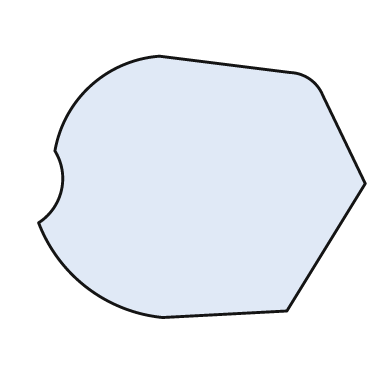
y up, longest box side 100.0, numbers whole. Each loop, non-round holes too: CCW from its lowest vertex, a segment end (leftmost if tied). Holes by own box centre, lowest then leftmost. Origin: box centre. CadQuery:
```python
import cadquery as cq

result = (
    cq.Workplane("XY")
    .moveTo(-12.0, -40.0)
    .lineTo(26.0, -38.0)
    .lineTo(50.0, 1.0)
    .lineTo(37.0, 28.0)
    .threePointArc((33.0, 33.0), (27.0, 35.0))
    .lineTo(-13.0, 40.0)
    .threePointArc((-34.0, 31.0), (-45.0, 11.0))
    .threePointArc((-43.0, -1.0), (-50.0, -11.0))
    .threePointArc((-35.0, -31.0), (-12.0, -40.0))
    .close()
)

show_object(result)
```